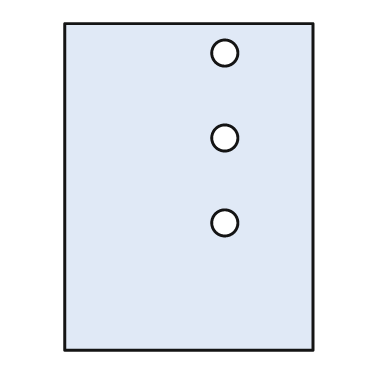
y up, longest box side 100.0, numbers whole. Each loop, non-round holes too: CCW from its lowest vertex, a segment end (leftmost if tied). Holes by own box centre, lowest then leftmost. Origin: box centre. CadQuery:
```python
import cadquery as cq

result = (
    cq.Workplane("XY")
    .moveTo(-38.0, -50.0)
    .lineTo(38.0, -50.0)
    .lineTo(38.0, 50.0)
    .lineTo(-38.0, 50.0)
    .close()
    .moveTo(11.0, -11.0)
    .circle(4.0)
    .moveTo(11.0, 15.0)
    .circle(4.0)
    .moveTo(11.0, 41.0)
    .circle(4.0)
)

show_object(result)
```